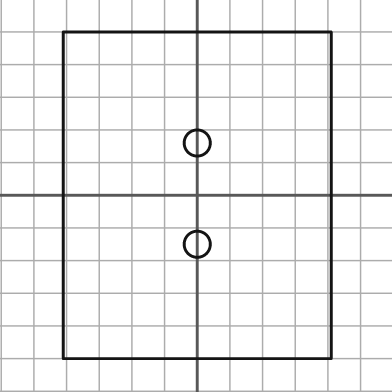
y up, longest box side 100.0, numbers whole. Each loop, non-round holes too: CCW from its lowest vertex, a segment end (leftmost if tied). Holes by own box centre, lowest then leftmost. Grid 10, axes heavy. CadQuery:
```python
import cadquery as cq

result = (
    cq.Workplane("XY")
    .moveTo(-41.0, -50.0)
    .lineTo(41.0, -50.0)
    .lineTo(41.0, 50.0)
    .lineTo(-41.0, 50.0)
    .close()
    .moveTo(0.0, -15.0)
    .circle(4.0)
    .moveTo(0.0, 16.0)
    .circle(4.0)
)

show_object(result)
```